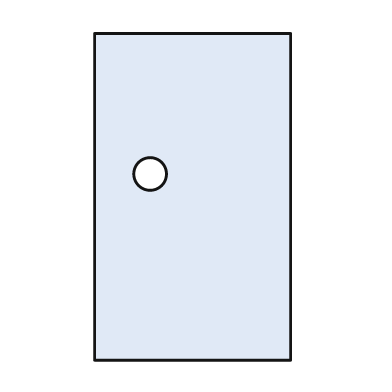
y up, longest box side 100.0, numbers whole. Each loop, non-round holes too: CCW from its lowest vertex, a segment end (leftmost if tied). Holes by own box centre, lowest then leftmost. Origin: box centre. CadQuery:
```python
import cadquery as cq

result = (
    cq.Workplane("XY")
    .moveTo(-30.0, -50.0)
    .lineTo(30.0, -50.0)
    .lineTo(30.0, 50.0)
    .lineTo(-30.0, 50.0)
    .close()
    .moveTo(-13.0, 7.0)
    .circle(5.0)
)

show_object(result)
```